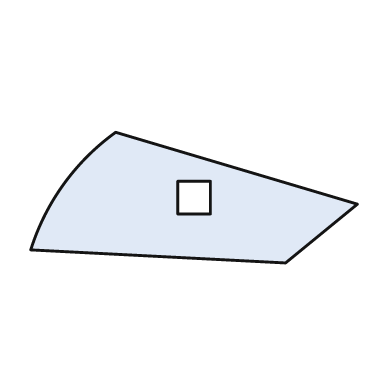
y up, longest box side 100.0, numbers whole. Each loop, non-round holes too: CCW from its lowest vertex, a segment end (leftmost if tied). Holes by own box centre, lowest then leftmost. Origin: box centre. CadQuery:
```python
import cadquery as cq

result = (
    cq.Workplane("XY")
    .moveTo(28.0, -20.0)
    .lineTo(50.0, -2.0)
    .lineTo(-24.0, 20.0)
    .threePointArc((-40.0, 4.0), (-50.0, -16.0))
    .close()
    .moveTo(-5.0, -5.0)
    .lineTo(5.0, -5.0)
    .lineTo(5.0, 5.0)
    .lineTo(-5.0, 5.0)
    .close()
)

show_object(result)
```